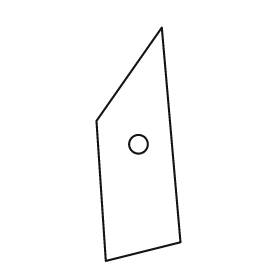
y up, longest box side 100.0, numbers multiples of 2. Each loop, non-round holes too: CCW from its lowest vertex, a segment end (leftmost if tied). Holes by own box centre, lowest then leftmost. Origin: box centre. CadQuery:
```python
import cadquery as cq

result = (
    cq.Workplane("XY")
    .moveTo(-14.0, -50.0)
    .lineTo(18.0, -42.0)
    .lineTo(10.0, 50.0)
    .lineTo(-18.0, 10.0)
    .close()
    .moveTo(0.0, 0.0)
    .circle(4.0)
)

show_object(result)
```